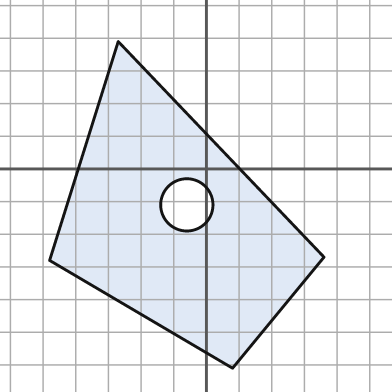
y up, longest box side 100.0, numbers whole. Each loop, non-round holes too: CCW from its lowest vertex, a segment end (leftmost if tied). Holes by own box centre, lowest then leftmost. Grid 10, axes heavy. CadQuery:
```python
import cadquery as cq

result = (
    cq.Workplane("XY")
    .moveTo(8.0, -61.0)
    .lineTo(36.0, -27.0)
    .lineTo(-27.0, 39.0)
    .lineTo(-48.0, -28.0)
    .close()
    .moveTo(-6.0, -11.0)
    .circle(8.0)
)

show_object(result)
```